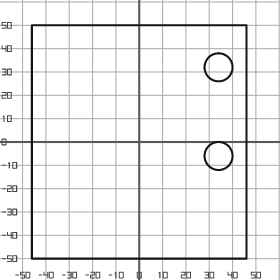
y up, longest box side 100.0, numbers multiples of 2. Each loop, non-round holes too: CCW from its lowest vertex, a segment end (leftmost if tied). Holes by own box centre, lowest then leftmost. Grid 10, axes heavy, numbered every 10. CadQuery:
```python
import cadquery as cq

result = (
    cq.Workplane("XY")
    .moveTo(-46.0, -50.0)
    .lineTo(46.0, -50.0)
    .lineTo(46.0, 50.0)
    .lineTo(-46.0, 50.0)
    .close()
    .moveTo(34.0, -6.0)
    .circle(6.0)
    .moveTo(34.0, 32.0)
    .circle(6.0)
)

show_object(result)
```